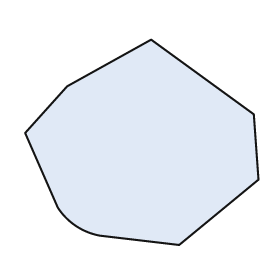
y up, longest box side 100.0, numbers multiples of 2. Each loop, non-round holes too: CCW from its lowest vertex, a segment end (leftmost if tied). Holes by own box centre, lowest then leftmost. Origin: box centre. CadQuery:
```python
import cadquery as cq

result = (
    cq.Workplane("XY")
    .moveTo(16.0, -44.0)
    .lineTo(50.0, -16.0)
    .lineTo(48.0, 12.0)
    .lineTo(4.0, 44.0)
    .lineTo(-32.0, 24.0)
    .lineTo(-50.0, 4.0)
    .lineTo(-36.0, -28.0)
    .threePointArc((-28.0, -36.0), (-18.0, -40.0))
    .close()
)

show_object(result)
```